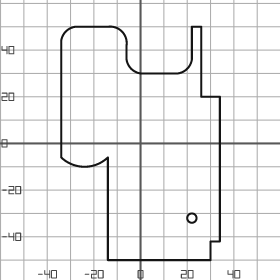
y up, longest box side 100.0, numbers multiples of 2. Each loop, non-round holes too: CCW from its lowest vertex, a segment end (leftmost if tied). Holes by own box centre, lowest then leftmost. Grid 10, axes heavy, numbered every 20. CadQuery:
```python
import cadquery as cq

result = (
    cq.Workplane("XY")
    .moveTo(-14.0, -50.0)
    .lineTo(30.0, -50.0)
    .lineTo(30.0, -42.0)
    .lineTo(34.0, -42.0)
    .lineTo(34.0, 20.0)
    .lineTo(26.0, 20.0)
    .lineTo(26.0, 50.0)
    .lineTo(22.0, 50.0)
    .lineTo(22.0, 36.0)
    .threePointArc((20.0, 32.0), (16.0, 30.0))
    .lineTo(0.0, 30.0)
    .threePointArc((-4.0, 32.0), (-6.0, 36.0))
    .lineTo(-6.0, 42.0)
    .threePointArc((-8.0, 48.0), (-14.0, 50.0))
    .lineTo(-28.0, 50.0)
    .threePointArc((-32.0, 48.0), (-34.0, 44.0))
    .lineTo(-34.0, -6.0)
    .threePointArc((-24.0, -10.0), (-14.0, -6.0))
    .close()
    .moveTo(22.0, -32.0)
    .circle(2.0)
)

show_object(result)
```